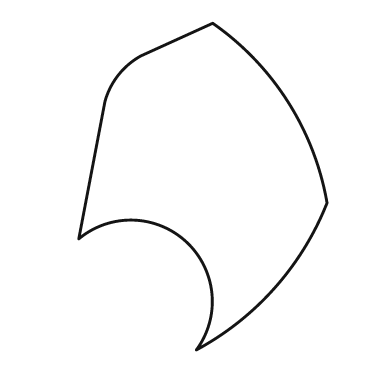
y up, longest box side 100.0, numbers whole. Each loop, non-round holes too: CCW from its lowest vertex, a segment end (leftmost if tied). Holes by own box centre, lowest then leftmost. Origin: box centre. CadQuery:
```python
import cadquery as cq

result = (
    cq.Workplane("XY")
    .moveTo(-2.0, -50.0)
    .threePointArc((22.0, -31.0), (38.0, -5.0))
    .threePointArc((26.0, 26.0), (3.0, 50.0))
    .lineTo(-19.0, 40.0)
    .threePointArc((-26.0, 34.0), (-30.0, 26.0))
    .lineTo(-38.0, -16.0)
    .threePointArc((-5.0, -17.0), (-2.0, -50.0))
    .close()
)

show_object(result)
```